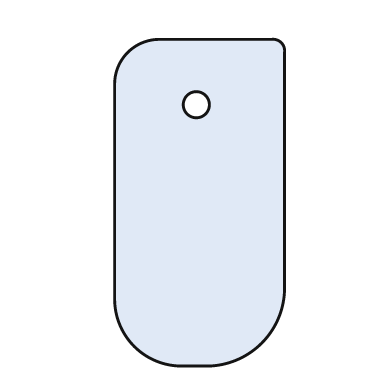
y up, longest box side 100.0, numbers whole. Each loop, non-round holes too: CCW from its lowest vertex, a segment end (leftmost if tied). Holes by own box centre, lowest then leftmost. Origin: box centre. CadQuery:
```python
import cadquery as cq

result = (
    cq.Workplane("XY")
    .moveTo(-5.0, -50.0)
    .lineTo(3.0, -50.0)
    .threePointArc((19.0, -43.0), (26.0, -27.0))
    .lineTo(26.0, 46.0)
    .threePointArc((25.0, 49.0), (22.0, 50.0))
    .lineTo(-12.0, 50.0)
    .threePointArc((-22.0, 46.0), (-26.0, 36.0))
    .lineTo(-26.0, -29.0)
    .threePointArc((-20.0, -44.0), (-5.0, -50.0))
    .close()
    .moveTo(-1.0, 30.0)
    .circle(4.0)
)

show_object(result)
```